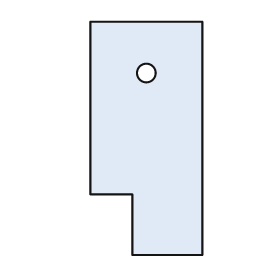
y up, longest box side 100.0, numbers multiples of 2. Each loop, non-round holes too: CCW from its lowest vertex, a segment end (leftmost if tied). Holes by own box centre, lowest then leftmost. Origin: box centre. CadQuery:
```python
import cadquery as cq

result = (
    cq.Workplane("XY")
    .moveTo(-6.0, -50.0)
    .lineTo(24.0, -50.0)
    .lineTo(24.0, 50.0)
    .lineTo(-24.0, 50.0)
    .lineTo(-24.0, -24.0)
    .lineTo(-6.0, -24.0)
    .close()
    .moveTo(0.0, 28.0)
    .circle(4.0)
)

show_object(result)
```